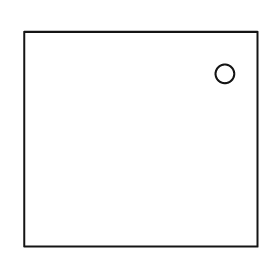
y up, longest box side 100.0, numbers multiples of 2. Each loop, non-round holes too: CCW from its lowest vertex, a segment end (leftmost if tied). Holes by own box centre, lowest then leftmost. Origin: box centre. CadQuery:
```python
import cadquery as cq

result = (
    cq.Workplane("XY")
    .moveTo(-50.0, -46.0)
    .lineTo(50.0, -46.0)
    .lineTo(50.0, 46.0)
    .lineTo(-50.0, 46.0)
    .close()
    .moveTo(36.0, 28.0)
    .circle(4.0)
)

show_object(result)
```